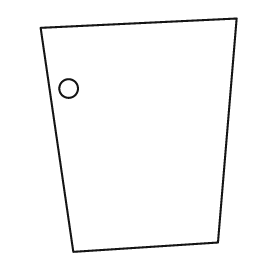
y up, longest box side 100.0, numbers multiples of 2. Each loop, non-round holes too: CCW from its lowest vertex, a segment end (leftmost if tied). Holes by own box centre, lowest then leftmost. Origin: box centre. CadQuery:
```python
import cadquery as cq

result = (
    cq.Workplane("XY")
    .moveTo(-28.0, -50.0)
    .lineTo(34.0, -46.0)
    .lineTo(42.0, 50.0)
    .lineTo(-42.0, 46.0)
    .close()
    .moveTo(-30.0, 20.0)
    .circle(4.0)
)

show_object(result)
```